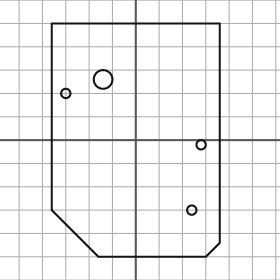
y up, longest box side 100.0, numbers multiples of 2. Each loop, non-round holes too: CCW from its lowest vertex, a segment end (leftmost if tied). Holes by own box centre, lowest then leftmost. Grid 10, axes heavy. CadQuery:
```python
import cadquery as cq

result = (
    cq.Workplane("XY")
    .moveTo(-16.0, -50.0)
    .lineTo(30.0, -50.0)
    .lineTo(36.0, -44.0)
    .lineTo(36.0, 50.0)
    .lineTo(-36.0, 50.0)
    .lineTo(-36.0, -30.0)
    .close()
    .moveTo(24.0, -30.0)
    .circle(2.0)
    .moveTo(28.0, -2.0)
    .circle(2.0)
    .moveTo(-30.0, 20.0)
    .circle(2.0)
    .moveTo(-14.0, 26.0)
    .circle(4.0)
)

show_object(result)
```